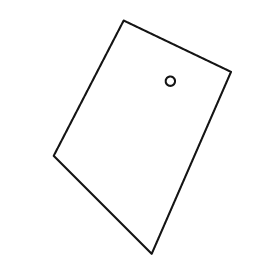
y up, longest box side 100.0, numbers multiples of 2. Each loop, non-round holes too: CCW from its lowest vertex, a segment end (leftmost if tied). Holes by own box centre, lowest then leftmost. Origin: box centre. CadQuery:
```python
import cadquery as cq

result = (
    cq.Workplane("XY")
    .moveTo(4.0, -50.0)
    .lineTo(38.0, 28.0)
    .lineTo(-8.0, 50.0)
    .lineTo(-38.0, -8.0)
    .close()
    .moveTo(12.0, 24.0)
    .circle(2.0)
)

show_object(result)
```